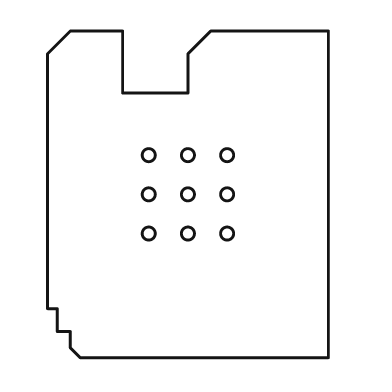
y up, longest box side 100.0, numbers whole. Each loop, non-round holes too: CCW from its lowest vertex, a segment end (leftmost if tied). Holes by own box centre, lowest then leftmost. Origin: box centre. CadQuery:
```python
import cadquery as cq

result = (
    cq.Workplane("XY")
    .moveTo(-33.0, -50.0)
    .lineTo(43.0, -50.0)
    .lineTo(43.0, 50.0)
    .lineTo(7.0, 50.0)
    .lineTo(0.0, 43.0)
    .lineTo(0.0, 31.0)
    .lineTo(-20.0, 31.0)
    .lineTo(-20.0, 50.0)
    .lineTo(-36.0, 50.0)
    .lineTo(-43.0, 43.0)
    .lineTo(-43.0, -35.0)
    .lineTo(-40.0, -35.0)
    .lineTo(-40.0, -42.0)
    .lineTo(-36.0, -42.0)
    .lineTo(-36.0, -47.0)
    .close()
    .moveTo(-12.0, -12.0)
    .circle(2.0)
    .moveTo(0.0, -12.0)
    .circle(2.0)
    .moveTo(12.0, -12.0)
    .circle(2.0)
    .moveTo(-12.0, 0.0)
    .circle(2.0)
    .moveTo(0.0, 0.0)
    .circle(2.0)
    .moveTo(12.0, 0.0)
    .circle(2.0)
    .moveTo(-12.0, 12.0)
    .circle(2.0)
    .moveTo(0.0, 12.0)
    .circle(2.0)
    .moveTo(12.0, 12.0)
    .circle(2.0)
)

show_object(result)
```